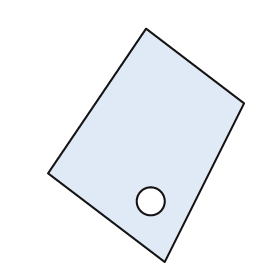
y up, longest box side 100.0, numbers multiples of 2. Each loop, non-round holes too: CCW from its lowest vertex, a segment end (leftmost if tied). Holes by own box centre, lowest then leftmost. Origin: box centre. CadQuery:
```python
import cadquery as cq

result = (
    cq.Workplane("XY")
    .moveTo(8.0, -50.0)
    .lineTo(42.0, 18.0)
    .lineTo(0.0, 50.0)
    .lineTo(-42.0, -12.0)
    .close()
    .moveTo(2.0, -24.0)
    .circle(6.0)
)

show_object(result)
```